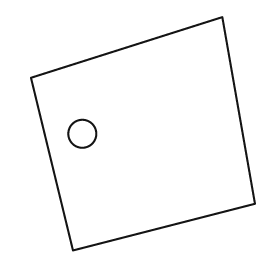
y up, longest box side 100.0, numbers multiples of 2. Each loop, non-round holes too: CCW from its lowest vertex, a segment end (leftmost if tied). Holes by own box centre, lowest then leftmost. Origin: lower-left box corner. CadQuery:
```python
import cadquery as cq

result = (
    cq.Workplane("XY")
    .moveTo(18.0, 0.0)
    .lineTo(96.0, 20.0)
    .lineTo(82.0, 100.0)
    .lineTo(0.0, 74.0)
    .close()
    .moveTo(22.0, 50.0)
    .circle(6.0)
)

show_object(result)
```